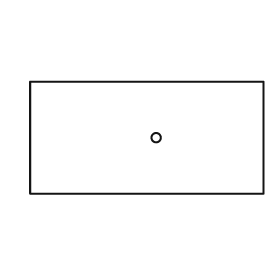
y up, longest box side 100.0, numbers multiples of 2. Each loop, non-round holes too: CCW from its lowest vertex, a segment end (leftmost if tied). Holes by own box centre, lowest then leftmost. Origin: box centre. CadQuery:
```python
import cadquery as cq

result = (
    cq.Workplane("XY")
    .moveTo(-50.0, -24.0)
    .lineTo(50.0, -24.0)
    .lineTo(50.0, 24.0)
    .lineTo(-50.0, 24.0)
    .close()
    .moveTo(4.0, 0.0)
    .circle(2.0)
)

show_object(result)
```